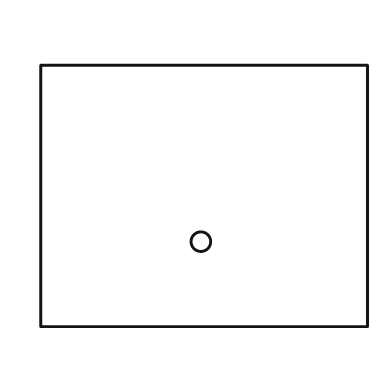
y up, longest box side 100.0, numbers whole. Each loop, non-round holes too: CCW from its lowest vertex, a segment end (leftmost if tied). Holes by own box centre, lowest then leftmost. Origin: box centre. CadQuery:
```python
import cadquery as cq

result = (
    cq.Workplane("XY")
    .moveTo(-50.0, -40.0)
    .lineTo(50.0, -40.0)
    .lineTo(50.0, 40.0)
    .lineTo(-50.0, 40.0)
    .close()
    .moveTo(-1.0, -14.0)
    .circle(3.0)
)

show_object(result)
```